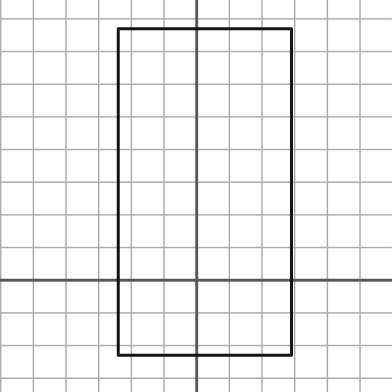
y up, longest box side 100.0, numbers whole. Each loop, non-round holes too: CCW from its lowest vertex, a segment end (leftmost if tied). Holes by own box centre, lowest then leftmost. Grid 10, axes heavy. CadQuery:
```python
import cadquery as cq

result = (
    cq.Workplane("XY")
    .moveTo(-24.0, -23.0)
    .lineTo(29.0, -23.0)
    .lineTo(29.0, 77.0)
    .lineTo(-24.0, 77.0)
    .close()
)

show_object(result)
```